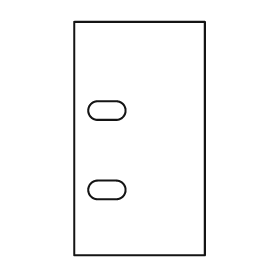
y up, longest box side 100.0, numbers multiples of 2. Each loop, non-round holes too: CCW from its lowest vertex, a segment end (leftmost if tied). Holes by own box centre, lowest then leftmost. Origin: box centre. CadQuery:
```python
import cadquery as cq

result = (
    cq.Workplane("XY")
    .moveTo(-28.0, -50.0)
    .lineTo(28.0, -50.0)
    .lineTo(28.0, 50.0)
    .lineTo(-28.0, 50.0)
    .close()
    .moveTo(-18.0, -26.0)
    .lineTo(-10.0, -26.0)
    .threePointArc((-6.0, -22.0), (-10.0, -18.0))
    .lineTo(-18.0, -18.0)
    .threePointArc((-22.0, -22.0), (-18.0, -26.0))
    .close()
    .moveTo(-18.0, 8.0)
    .lineTo(-10.0, 8.0)
    .threePointArc((-6.0, 12.0), (-10.0, 16.0))
    .lineTo(-18.0, 16.0)
    .threePointArc((-22.0, 12.0), (-18.0, 8.0))
    .close()
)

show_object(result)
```